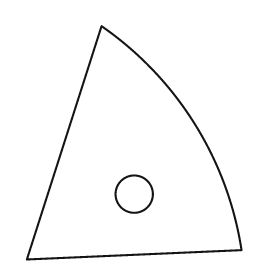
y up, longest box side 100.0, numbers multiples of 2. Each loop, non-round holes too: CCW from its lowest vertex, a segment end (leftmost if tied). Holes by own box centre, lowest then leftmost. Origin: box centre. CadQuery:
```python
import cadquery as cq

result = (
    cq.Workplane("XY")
    .moveTo(-46.0, -50.0)
    .lineTo(46.0, -46.0)
    .threePointArc((26.0, 8.0), (-14.0, 50.0))
    .close()
    .moveTo(0.0, -22.0)
    .circle(8.0)
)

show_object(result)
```